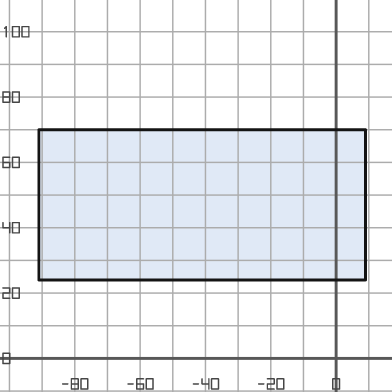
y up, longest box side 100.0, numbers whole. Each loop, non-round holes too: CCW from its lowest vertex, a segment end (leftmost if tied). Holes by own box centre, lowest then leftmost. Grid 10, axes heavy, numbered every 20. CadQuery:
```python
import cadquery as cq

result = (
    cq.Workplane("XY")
    .moveTo(-91.0, 24.0)
    .lineTo(9.0, 24.0)
    .lineTo(9.0, 70.0)
    .lineTo(-91.0, 70.0)
    .close()
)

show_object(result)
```